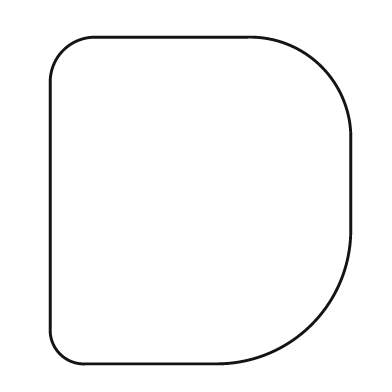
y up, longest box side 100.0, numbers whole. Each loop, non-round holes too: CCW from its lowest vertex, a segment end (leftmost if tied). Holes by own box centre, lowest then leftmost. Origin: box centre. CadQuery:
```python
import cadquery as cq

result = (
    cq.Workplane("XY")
    .moveTo(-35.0, -50.0)
    .lineTo(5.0, -50.0)
    .threePointArc((34.0, -38.0), (46.0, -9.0))
    .lineTo(46.0, 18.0)
    .threePointArc((37.0, 41.0), (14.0, 50.0))
    .lineTo(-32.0, 50.0)
    .threePointArc((-42.0, 46.0), (-46.0, 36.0))
    .lineTo(-46.0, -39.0)
    .threePointArc((-43.0, -47.0), (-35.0, -50.0))
    .close()
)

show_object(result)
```